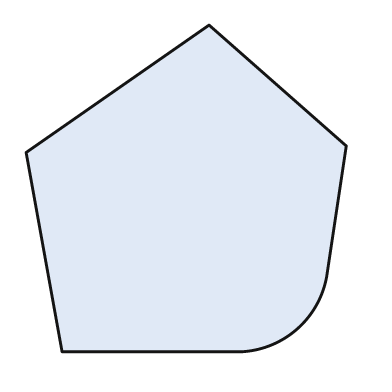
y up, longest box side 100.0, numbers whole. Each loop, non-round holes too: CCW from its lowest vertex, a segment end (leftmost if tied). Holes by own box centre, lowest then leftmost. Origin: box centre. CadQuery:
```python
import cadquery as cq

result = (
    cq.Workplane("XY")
    .moveTo(-38.0, -50.0)
    .lineTo(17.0, -50.0)
    .threePointArc((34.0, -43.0), (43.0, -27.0))
    .lineTo(49.0, 13.0)
    .lineTo(7.0, 50.0)
    .lineTo(-49.0, 11.0)
    .close()
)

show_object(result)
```